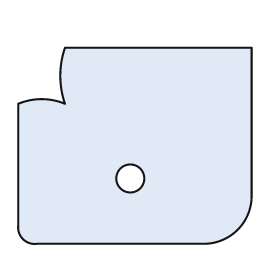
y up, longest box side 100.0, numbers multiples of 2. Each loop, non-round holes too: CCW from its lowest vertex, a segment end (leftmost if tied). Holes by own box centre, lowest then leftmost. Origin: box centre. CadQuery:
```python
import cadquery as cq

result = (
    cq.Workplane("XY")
    .moveTo(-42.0, -42.0)
    .lineTo(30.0, -42.0)
    .threePointArc((44.0, -36.0), (50.0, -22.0))
    .lineTo(50.0, 42.0)
    .lineTo(-30.0, 42.0)
    .threePointArc((-32.0, 30.0), (-30.0, 18.0))
    .threePointArc((-40.0, 20.0), (-50.0, 18.0))
    .lineTo(-50.0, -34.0)
    .threePointArc((-48.0, -40.0), (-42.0, -42.0))
    .close()
    .moveTo(-2.0, -14.0)
    .circle(6.0)
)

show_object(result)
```